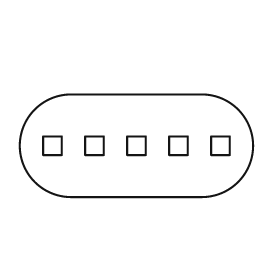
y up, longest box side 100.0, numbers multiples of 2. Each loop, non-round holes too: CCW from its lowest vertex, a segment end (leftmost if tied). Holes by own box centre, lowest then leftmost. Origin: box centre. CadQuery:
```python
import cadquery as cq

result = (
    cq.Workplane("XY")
    .moveTo(-28.0, -22.0)
    .lineTo(28.0, -22.0)
    .threePointArc((50.0, 0.0), (28.0, 22.0))
    .lineTo(-28.0, 22.0)
    .threePointArc((-50.0, 0.0), (-28.0, -22.0))
    .close()
    .moveTo(-40.0, -4.0)
    .lineTo(-32.0, -4.0)
    .lineTo(-32.0, 4.0)
    .lineTo(-40.0, 4.0)
    .close()
    .moveTo(-22.0, -4.0)
    .lineTo(-14.0, -4.0)
    .lineTo(-14.0, 4.0)
    .lineTo(-22.0, 4.0)
    .close()
    .moveTo(-4.0, -4.0)
    .lineTo(4.0, -4.0)
    .lineTo(4.0, 4.0)
    .lineTo(-4.0, 4.0)
    .close()
    .moveTo(14.0, -4.0)
    .lineTo(22.0, -4.0)
    .lineTo(22.0, 4.0)
    .lineTo(14.0, 4.0)
    .close()
    .moveTo(32.0, -4.0)
    .lineTo(40.0, -4.0)
    .lineTo(40.0, 4.0)
    .lineTo(32.0, 4.0)
    .close()
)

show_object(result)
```